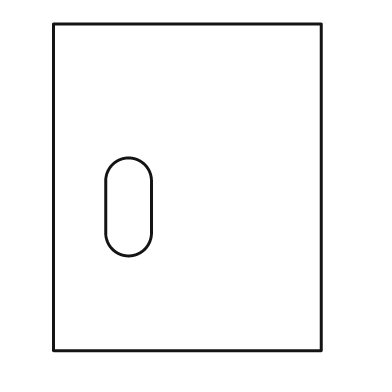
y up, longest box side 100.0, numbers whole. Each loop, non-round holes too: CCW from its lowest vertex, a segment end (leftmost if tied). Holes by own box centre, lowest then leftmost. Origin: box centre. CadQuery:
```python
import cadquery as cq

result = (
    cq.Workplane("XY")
    .moveTo(-41.0, -50.0)
    .lineTo(41.0, -50.0)
    .lineTo(41.0, 50.0)
    .lineTo(-41.0, 50.0)
    .close()
    .moveTo(-25.0, -14.0)
    .threePointArc((-18.0, -21.0), (-11.0, -14.0))
    .lineTo(-11.0, 2.0)
    .threePointArc((-18.0, 9.0), (-25.0, 2.0))
    .close()
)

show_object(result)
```